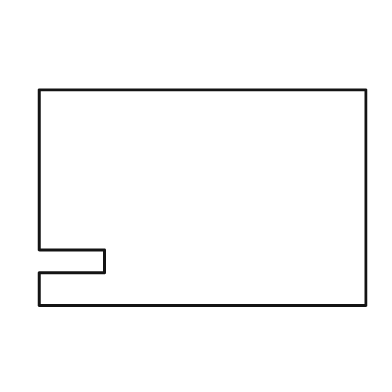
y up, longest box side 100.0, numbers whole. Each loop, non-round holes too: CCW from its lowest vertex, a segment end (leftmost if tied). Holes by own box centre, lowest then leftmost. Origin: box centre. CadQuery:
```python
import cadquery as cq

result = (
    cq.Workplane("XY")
    .moveTo(-50.0, -33.0)
    .lineTo(50.0, -33.0)
    .lineTo(50.0, 33.0)
    .lineTo(-50.0, 33.0)
    .lineTo(-50.0, -16.0)
    .lineTo(-30.0, -16.0)
    .lineTo(-30.0, -23.0)
    .lineTo(-50.0, -23.0)
    .close()
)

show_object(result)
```